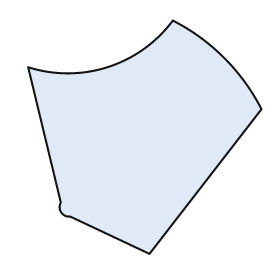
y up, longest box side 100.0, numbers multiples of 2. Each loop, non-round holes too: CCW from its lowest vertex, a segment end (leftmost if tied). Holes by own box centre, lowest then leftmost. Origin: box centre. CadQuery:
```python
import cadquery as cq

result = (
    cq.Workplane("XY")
    .moveTo(2.0, -50.0)
    .lineTo(50.0, 12.0)
    .threePointArc((34.0, 34.0), (12.0, 50.0))
    .threePointArc((-16.0, 30.0), (-50.0, 30.0))
    .lineTo(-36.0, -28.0)
    .threePointArc((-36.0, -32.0), (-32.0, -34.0))
    .close()
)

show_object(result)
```